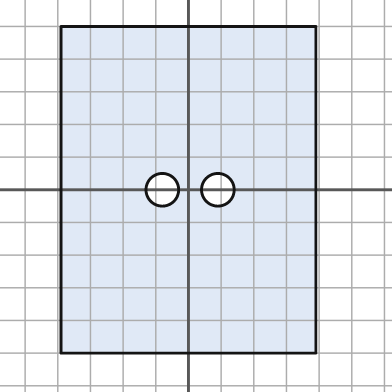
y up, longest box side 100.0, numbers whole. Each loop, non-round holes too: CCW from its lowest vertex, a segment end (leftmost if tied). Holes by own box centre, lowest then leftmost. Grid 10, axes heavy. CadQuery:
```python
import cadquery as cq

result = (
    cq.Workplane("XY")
    .moveTo(-39.0, -50.0)
    .lineTo(39.0, -50.0)
    .lineTo(39.0, 50.0)
    .lineTo(-39.0, 50.0)
    .close()
    .moveTo(-8.0, 0.0)
    .circle(5.0)
    .moveTo(9.0, 0.0)
    .circle(5.0)
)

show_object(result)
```